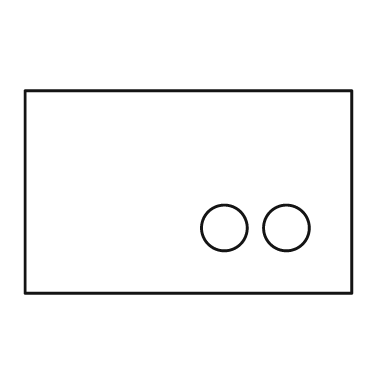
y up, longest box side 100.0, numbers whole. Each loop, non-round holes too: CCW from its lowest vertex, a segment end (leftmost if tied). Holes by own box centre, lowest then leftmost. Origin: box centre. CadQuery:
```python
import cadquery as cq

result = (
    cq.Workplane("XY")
    .moveTo(-50.0, -31.0)
    .lineTo(50.0, -31.0)
    .lineTo(50.0, 31.0)
    .lineTo(-50.0, 31.0)
    .close()
    .moveTo(11.0, -11.0)
    .circle(7.0)
    .moveTo(30.0, -11.0)
    .circle(7.0)
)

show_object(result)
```